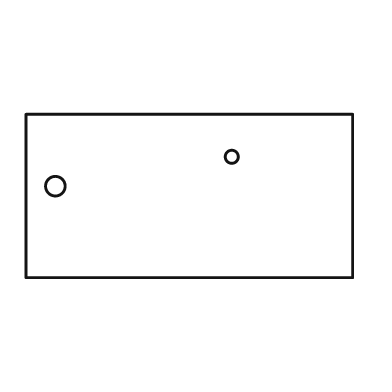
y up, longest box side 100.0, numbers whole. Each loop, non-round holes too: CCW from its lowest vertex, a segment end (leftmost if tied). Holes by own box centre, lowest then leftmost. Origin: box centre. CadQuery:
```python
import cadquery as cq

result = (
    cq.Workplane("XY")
    .moveTo(-50.0, -25.0)
    .lineTo(50.0, -25.0)
    .lineTo(50.0, 25.0)
    .lineTo(-50.0, 25.0)
    .close()
    .moveTo(-41.0, 3.0)
    .circle(3.0)
    .moveTo(13.0, 12.0)
    .circle(2.0)
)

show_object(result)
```